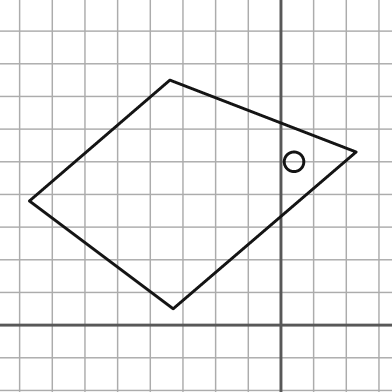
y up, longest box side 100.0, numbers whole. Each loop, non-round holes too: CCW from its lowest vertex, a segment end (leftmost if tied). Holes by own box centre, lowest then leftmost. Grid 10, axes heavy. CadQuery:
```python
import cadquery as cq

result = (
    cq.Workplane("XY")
    .moveTo(-33.0, 5.0)
    .lineTo(23.0, 53.0)
    .lineTo(-34.0, 75.0)
    .lineTo(-77.0, 38.0)
    .close()
    .moveTo(4.0, 50.0)
    .circle(3.0)
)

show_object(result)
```